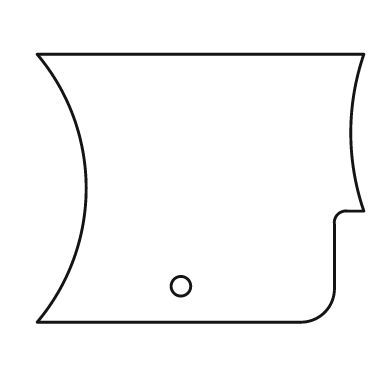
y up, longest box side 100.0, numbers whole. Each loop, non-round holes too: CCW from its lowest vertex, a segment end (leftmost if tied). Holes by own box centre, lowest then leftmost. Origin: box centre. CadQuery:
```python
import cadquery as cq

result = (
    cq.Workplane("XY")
    .moveTo(-50.0, -41.0)
    .lineTo(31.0, -41.0)
    .threePointArc((38.0, -38.0), (41.0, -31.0))
    .lineTo(41.0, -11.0)
    .threePointArc((42.0, -8.0), (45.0, -7.0))
    .lineTo(50.0, -7.0)
    .threePointArc((46.0, 17.0), (50.0, 41.0))
    .lineTo(-50.0, 41.0)
    .threePointArc((-35.0, 0.0), (-50.0, -41.0))
    .close()
    .moveTo(-6.0, -30.0)
    .circle(3.0)
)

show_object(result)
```